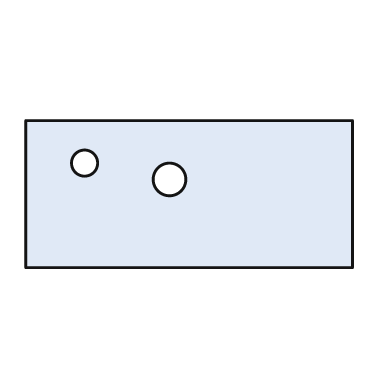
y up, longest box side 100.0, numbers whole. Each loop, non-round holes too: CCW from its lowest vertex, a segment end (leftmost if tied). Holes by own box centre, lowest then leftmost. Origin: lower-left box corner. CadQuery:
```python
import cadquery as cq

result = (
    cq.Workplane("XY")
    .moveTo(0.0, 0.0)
    .lineTo(100.0, 0.0)
    .lineTo(100.0, 45.0)
    .lineTo(0.0, 45.0)
    .close()
    .moveTo(44.0, 27.0)
    .circle(5.0)
    .moveTo(18.0, 32.0)
    .circle(4.0)
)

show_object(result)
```